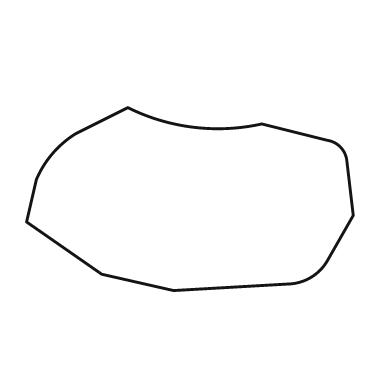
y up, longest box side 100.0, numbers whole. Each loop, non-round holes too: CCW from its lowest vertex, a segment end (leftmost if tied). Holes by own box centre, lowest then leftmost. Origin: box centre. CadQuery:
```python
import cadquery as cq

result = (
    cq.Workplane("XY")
    .moveTo(-5.0, -28.0)
    .lineTo(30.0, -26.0)
    .threePointArc((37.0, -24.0), (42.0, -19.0))
    .lineTo(50.0, -5.0)
    .lineTo(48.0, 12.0)
    .threePointArc((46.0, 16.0), (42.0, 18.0))
    .lineTo(22.0, 23.0)
    .threePointArc((1.0, 22.0), (-19.0, 28.0))
    .lineTo(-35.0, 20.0)
    .threePointArc((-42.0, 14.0), (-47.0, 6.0))
    .lineTo(-50.0, -7.0)
    .lineTo(-27.0, -23.0)
    .close()
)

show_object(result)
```